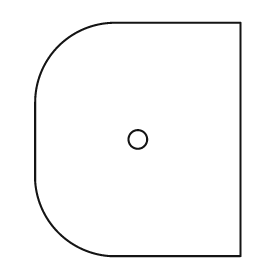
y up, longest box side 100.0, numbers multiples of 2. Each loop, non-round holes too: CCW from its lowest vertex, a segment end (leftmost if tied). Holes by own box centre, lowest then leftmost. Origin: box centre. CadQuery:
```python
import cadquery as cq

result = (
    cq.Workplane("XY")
    .moveTo(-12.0, -50.0)
    .lineTo(44.0, -50.0)
    .lineTo(44.0, 50.0)
    .lineTo(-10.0, 50.0)
    .threePointArc((-34.0, 40.0), (-44.0, 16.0))
    .lineTo(-44.0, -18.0)
    .threePointArc((-34.0, -40.0), (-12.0, -50.0))
    .close()
    .moveTo(0.0, 0.0)
    .circle(4.0)
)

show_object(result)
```